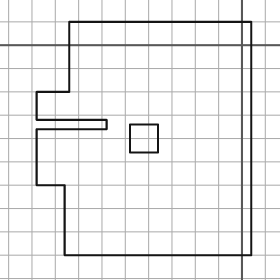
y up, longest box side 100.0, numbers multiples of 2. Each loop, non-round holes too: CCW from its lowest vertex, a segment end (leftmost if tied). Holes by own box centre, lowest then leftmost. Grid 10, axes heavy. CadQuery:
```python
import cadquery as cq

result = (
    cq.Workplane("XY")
    .moveTo(-76.0, -90.0)
    .lineTo(4.0, -90.0)
    .lineTo(4.0, 10.0)
    .lineTo(-74.0, 10.0)
    .lineTo(-74.0, -20.0)
    .lineTo(-88.0, -20.0)
    .lineTo(-88.0, -32.0)
    .lineTo(-58.0, -32.0)
    .lineTo(-58.0, -36.0)
    .lineTo(-88.0, -36.0)
    .lineTo(-88.0, -60.0)
    .lineTo(-76.0, -60.0)
    .close()
    .moveTo(-48.0, -46.0)
    .lineTo(-36.0, -46.0)
    .lineTo(-36.0, -34.0)
    .lineTo(-48.0, -34.0)
    .close()
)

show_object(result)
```